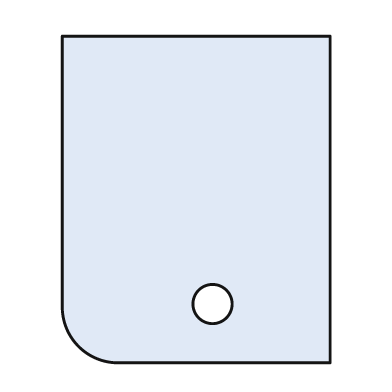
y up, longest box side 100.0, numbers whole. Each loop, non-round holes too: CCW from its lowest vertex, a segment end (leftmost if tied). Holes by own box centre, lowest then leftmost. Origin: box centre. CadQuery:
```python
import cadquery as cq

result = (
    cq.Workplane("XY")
    .moveTo(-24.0, -50.0)
    .lineTo(41.0, -50.0)
    .lineTo(41.0, 50.0)
    .lineTo(-41.0, 50.0)
    .lineTo(-41.0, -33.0)
    .threePointArc((-36.0, -45.0), (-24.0, -50.0))
    .close()
    .moveTo(5.0, -32.0)
    .circle(6.0)
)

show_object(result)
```